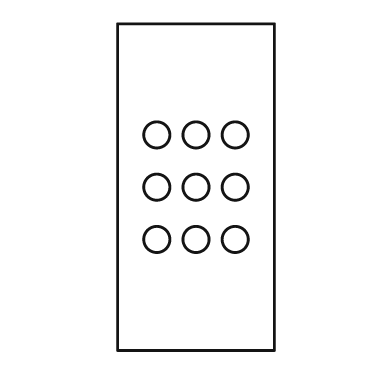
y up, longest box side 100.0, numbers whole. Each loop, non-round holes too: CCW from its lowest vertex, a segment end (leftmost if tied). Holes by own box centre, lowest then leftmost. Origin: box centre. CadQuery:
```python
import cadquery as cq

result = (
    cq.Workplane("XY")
    .moveTo(-24.0, -50.0)
    .lineTo(24.0, -50.0)
    .lineTo(24.0, 50.0)
    .lineTo(-24.0, 50.0)
    .close()
    .moveTo(-12.0, -16.0)
    .circle(4.0)
    .moveTo(0.0, -16.0)
    .circle(4.0)
    .moveTo(12.0, -16.0)
    .circle(4.0)
    .moveTo(-12.0, 0.0)
    .circle(4.0)
    .moveTo(0.0, 0.0)
    .circle(4.0)
    .moveTo(12.0, 0.0)
    .circle(4.0)
    .moveTo(-12.0, 16.0)
    .circle(4.0)
    .moveTo(0.0, 16.0)
    .circle(4.0)
    .moveTo(12.0, 16.0)
    .circle(4.0)
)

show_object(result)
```